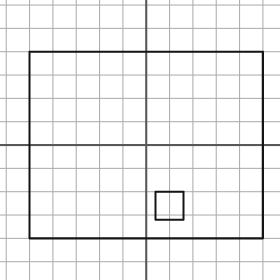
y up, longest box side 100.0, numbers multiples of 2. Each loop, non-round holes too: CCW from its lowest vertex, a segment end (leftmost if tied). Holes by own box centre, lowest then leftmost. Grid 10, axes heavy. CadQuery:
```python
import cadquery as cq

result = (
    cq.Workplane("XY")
    .moveTo(-50.0, -40.0)
    .lineTo(50.0, -40.0)
    .lineTo(50.0, 40.0)
    .lineTo(-50.0, 40.0)
    .close()
    .moveTo(4.0, -32.0)
    .lineTo(16.0, -32.0)
    .lineTo(16.0, -20.0)
    .lineTo(4.0, -20.0)
    .close()
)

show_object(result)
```